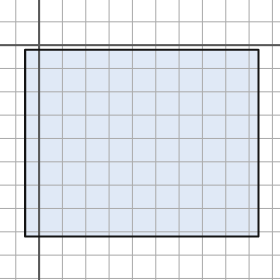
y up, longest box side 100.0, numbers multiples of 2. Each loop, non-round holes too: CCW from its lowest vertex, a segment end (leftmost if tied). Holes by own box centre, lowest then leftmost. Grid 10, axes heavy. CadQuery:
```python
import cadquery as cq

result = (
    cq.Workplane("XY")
    .moveTo(-6.0, -82.0)
    .lineTo(94.0, -82.0)
    .lineTo(94.0, -2.0)
    .lineTo(-6.0, -2.0)
    .close()
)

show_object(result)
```